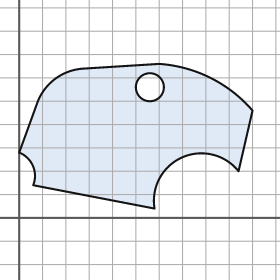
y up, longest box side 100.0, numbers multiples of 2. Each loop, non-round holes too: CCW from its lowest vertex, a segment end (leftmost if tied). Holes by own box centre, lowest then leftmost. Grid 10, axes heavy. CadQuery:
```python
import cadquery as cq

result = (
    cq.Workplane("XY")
    .moveTo(58.0, 4.0)
    .threePointArc((70.0, 26.0), (94.0, 20.0))
    .lineTo(100.0, 46.0)
    .threePointArc((82.0, 60.0), (60.0, 66.0))
    .lineTo(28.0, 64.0)
    .threePointArc((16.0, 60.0), (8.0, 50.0))
    .lineTo(0.0, 28.0)
    .threePointArc((6.0, 22.0), (6.0, 14.0))
    .close()
    .moveTo(56.0, 56.0)
    .circle(6.0)
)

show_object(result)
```